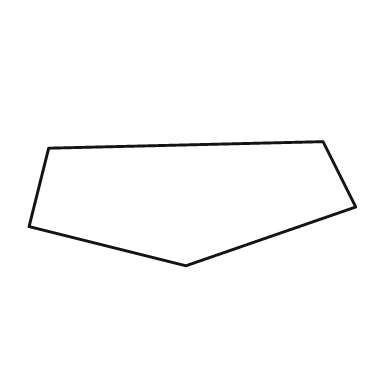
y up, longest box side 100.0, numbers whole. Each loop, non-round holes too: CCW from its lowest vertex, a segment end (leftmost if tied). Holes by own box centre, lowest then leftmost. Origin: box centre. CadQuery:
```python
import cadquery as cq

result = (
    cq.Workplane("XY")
    .moveTo(-2.0, -19.0)
    .lineTo(50.0, -1.0)
    .lineTo(40.0, 19.0)
    .lineTo(-44.0, 17.0)
    .lineTo(-50.0, -7.0)
    .close()
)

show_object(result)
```